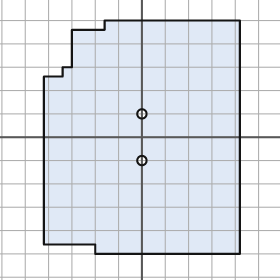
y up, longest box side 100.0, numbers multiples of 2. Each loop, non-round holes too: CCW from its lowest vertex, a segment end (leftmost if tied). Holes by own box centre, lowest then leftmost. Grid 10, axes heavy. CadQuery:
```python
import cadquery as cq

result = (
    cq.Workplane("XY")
    .moveTo(-20.0, -50.0)
    .lineTo(42.0, -50.0)
    .lineTo(42.0, 50.0)
    .lineTo(-16.0, 50.0)
    .lineTo(-16.0, 46.0)
    .lineTo(-30.0, 46.0)
    .lineTo(-30.0, 30.0)
    .lineTo(-34.0, 30.0)
    .lineTo(-34.0, 26.0)
    .lineTo(-42.0, 26.0)
    .lineTo(-42.0, -46.0)
    .lineTo(-20.0, -46.0)
    .close()
    .moveTo(0.0, -10.0)
    .circle(2.0)
    .moveTo(0.0, 10.0)
    .circle(2.0)
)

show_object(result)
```